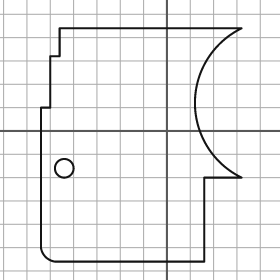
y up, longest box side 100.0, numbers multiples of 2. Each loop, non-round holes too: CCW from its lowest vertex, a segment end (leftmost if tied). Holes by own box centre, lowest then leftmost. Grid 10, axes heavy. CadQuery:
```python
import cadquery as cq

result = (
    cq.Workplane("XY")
    .moveTo(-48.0, -56.0)
    .lineTo(16.0, -56.0)
    .lineTo(16.0, -20.0)
    .lineTo(32.0, -20.0)
    .threePointArc((12.0, 12.0), (32.0, 44.0))
    .lineTo(-46.0, 44.0)
    .lineTo(-46.0, 32.0)
    .lineTo(-50.0, 32.0)
    .lineTo(-50.0, 10.0)
    .lineTo(-54.0, 10.0)
    .lineTo(-54.0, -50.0)
    .threePointArc((-52.0, -54.0), (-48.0, -56.0))
    .close()
    .moveTo(-44.0, -16.0)
    .circle(4.0)
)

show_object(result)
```